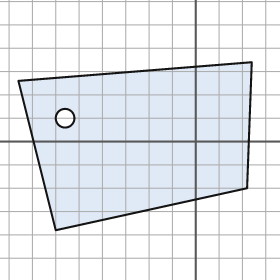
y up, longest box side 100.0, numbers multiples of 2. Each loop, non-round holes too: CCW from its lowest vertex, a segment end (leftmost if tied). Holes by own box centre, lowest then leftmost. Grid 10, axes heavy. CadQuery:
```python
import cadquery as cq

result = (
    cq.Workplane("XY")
    .moveTo(-60.0, -38.0)
    .lineTo(22.0, -20.0)
    .lineTo(24.0, 34.0)
    .lineTo(-76.0, 26.0)
    .close()
    .moveTo(-56.0, 10.0)
    .circle(4.0)
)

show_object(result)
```